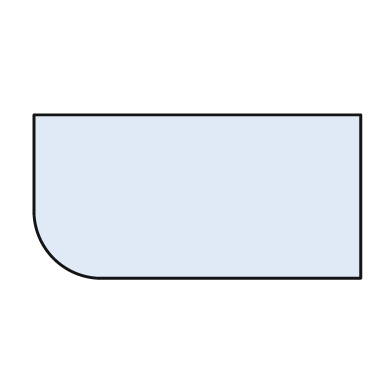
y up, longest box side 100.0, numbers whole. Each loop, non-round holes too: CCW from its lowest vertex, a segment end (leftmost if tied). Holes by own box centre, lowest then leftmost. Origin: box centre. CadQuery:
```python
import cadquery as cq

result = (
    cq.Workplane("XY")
    .moveTo(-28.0, -25.0)
    .lineTo(50.0, -25.0)
    .lineTo(50.0, 25.0)
    .lineTo(-50.0, 25.0)
    .lineTo(-50.0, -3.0)
    .threePointArc((-44.0, -19.0), (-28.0, -25.0))
    .close()
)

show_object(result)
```